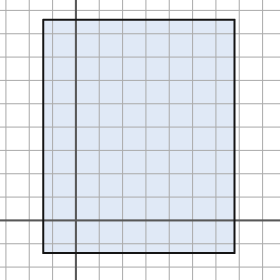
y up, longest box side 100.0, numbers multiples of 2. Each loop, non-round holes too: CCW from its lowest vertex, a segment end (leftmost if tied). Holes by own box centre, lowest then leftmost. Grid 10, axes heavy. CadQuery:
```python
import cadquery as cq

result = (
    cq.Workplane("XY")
    .moveTo(-14.0, -14.0)
    .lineTo(68.0, -14.0)
    .lineTo(68.0, 86.0)
    .lineTo(-14.0, 86.0)
    .close()
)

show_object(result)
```